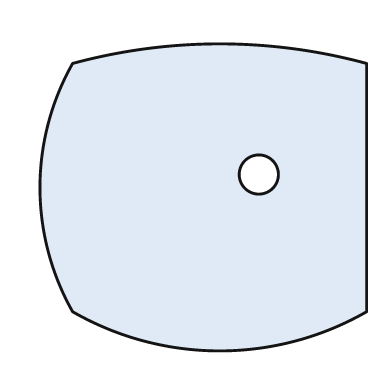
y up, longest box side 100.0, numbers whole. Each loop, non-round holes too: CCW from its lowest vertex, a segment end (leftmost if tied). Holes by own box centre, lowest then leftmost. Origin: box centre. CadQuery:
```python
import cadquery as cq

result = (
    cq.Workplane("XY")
    .moveTo(-40.0, -35.0)
    .threePointArc((5.0, -47.0), (50.0, -35.0))
    .lineTo(50.0, 41.0)
    .threePointArc((5.0, 47.0), (-40.0, 41.0))
    .threePointArc((-50.0, 3.0), (-40.0, -35.0))
    .close()
    .moveTo(17.0, 7.0)
    .circle(6.0)
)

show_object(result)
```